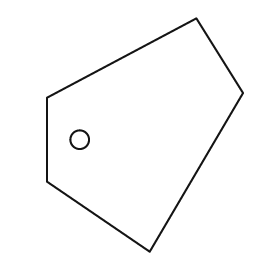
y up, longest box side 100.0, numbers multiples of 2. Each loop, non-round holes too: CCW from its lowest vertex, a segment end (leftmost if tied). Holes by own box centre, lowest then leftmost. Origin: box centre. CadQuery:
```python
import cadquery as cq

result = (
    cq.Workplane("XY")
    .moveTo(2.0, -50.0)
    .lineTo(42.0, 18.0)
    .lineTo(22.0, 50.0)
    .lineTo(-42.0, 16.0)
    .lineTo(-42.0, -20.0)
    .close()
    .moveTo(-28.0, -2.0)
    .circle(4.0)
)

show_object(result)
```